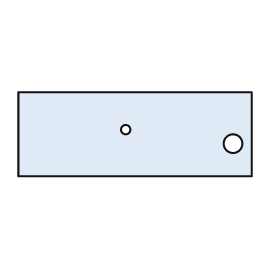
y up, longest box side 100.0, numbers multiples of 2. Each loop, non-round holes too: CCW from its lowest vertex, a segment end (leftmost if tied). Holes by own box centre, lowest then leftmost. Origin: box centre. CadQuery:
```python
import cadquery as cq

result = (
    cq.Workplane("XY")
    .moveTo(-50.0, -18.0)
    .lineTo(50.0, -18.0)
    .lineTo(50.0, 18.0)
    .lineTo(-50.0, 18.0)
    .close()
    .moveTo(42.0, -4.0)
    .circle(4.0)
    .moveTo(-4.0, 2.0)
    .circle(2.0)
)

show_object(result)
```